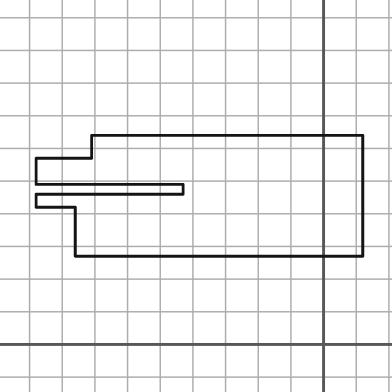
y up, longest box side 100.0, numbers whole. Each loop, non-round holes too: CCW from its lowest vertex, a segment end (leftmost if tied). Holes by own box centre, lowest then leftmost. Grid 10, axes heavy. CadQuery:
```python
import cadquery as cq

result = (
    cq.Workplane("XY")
    .moveTo(-76.0, 27.0)
    .lineTo(12.0, 27.0)
    .lineTo(12.0, 64.0)
    .lineTo(-71.0, 64.0)
    .lineTo(-71.0, 57.0)
    .lineTo(-88.0, 57.0)
    .lineTo(-88.0, 49.0)
    .lineTo(-43.0, 49.0)
    .lineTo(-43.0, 46.0)
    .lineTo(-88.0, 46.0)
    .lineTo(-88.0, 42.0)
    .lineTo(-76.0, 42.0)
    .close()
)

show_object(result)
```